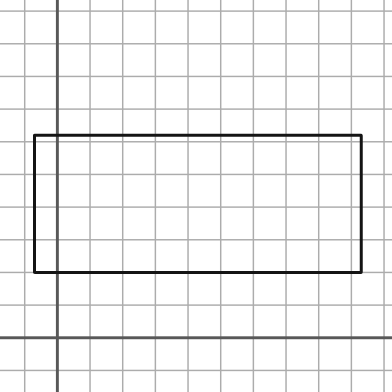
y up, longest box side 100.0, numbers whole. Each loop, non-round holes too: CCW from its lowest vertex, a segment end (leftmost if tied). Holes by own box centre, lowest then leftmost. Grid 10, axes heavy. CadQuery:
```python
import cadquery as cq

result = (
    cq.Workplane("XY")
    .moveTo(-7.0, 20.0)
    .lineTo(93.0, 20.0)
    .lineTo(93.0, 62.0)
    .lineTo(-7.0, 62.0)
    .close()
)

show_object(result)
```